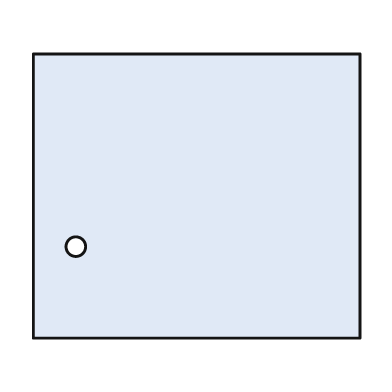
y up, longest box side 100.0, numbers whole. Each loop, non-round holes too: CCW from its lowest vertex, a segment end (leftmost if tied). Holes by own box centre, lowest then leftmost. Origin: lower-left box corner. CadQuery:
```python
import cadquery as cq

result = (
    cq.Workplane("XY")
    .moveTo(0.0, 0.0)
    .lineTo(100.0, 0.0)
    .lineTo(100.0, 87.0)
    .lineTo(0.0, 87.0)
    .close()
    .moveTo(13.0, 28.0)
    .circle(3.0)
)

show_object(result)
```